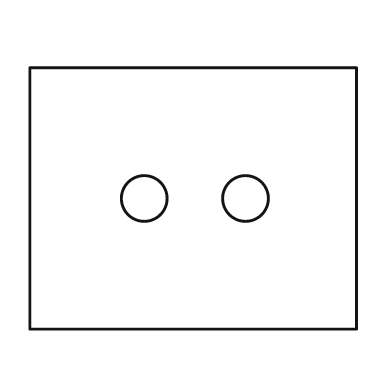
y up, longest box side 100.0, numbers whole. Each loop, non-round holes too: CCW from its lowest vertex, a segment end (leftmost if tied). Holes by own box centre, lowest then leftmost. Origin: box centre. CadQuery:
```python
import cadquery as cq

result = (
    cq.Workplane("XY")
    .moveTo(-50.0, -40.0)
    .lineTo(50.0, -40.0)
    .lineTo(50.0, 40.0)
    .lineTo(-50.0, 40.0)
    .close()
    .moveTo(-15.0, 0.0)
    .circle(7.0)
    .moveTo(16.0, 0.0)
    .circle(7.0)
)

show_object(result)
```